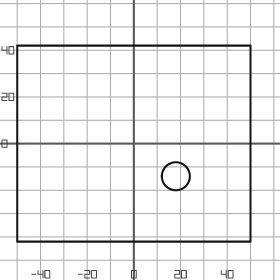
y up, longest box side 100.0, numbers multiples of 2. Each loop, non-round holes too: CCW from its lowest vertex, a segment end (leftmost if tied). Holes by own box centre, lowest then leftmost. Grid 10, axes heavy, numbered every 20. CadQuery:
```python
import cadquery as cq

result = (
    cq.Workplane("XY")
    .moveTo(-50.0, -42.0)
    .lineTo(50.0, -42.0)
    .lineTo(50.0, 42.0)
    .lineTo(-50.0, 42.0)
    .close()
    .moveTo(18.0, -14.0)
    .circle(6.0)
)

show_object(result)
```